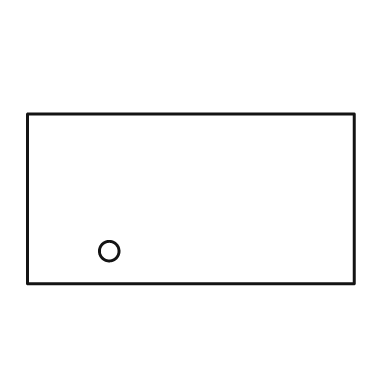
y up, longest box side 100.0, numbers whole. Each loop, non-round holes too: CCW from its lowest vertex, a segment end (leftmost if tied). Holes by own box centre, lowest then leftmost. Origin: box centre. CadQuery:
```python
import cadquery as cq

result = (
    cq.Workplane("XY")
    .moveTo(-50.0, -26.0)
    .lineTo(50.0, -26.0)
    .lineTo(50.0, 26.0)
    .lineTo(-50.0, 26.0)
    .close()
    .moveTo(-25.0, -16.0)
    .circle(3.0)
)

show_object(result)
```